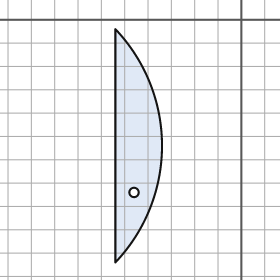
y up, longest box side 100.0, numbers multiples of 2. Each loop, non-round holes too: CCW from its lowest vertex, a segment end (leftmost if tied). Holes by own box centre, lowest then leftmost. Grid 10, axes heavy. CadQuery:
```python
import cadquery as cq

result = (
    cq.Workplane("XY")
    .moveTo(-54.0, -104.0)
    .threePointArc((-34.0, -54.0), (-54.0, -4.0))
    .close()
    .moveTo(-46.0, -74.0)
    .circle(2.0)
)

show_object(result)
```